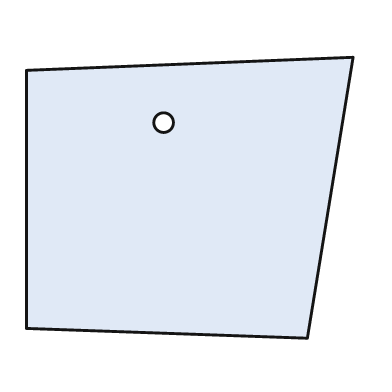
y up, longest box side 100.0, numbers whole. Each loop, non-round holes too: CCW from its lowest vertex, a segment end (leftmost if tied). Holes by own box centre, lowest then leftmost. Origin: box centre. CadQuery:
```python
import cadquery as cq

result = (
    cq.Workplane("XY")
    .moveTo(36.0, -43.0)
    .lineTo(50.0, 43.0)
    .lineTo(-50.0, 39.0)
    .lineTo(-50.0, -40.0)
    .close()
    .moveTo(-8.0, 23.0)
    .circle(3.0)
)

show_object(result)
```